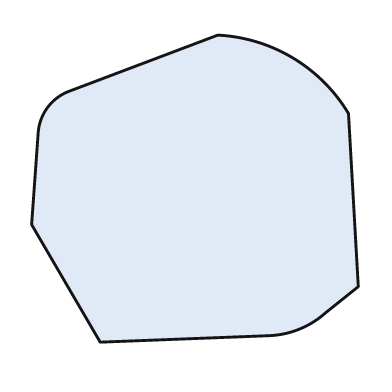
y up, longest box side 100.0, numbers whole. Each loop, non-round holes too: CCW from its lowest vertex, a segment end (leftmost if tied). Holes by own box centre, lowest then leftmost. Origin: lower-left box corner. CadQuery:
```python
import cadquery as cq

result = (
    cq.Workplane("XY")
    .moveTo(21.0, 0.0)
    .lineTo(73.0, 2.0)
    .threePointArc((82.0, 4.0), (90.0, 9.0))
    .lineTo(100.0, 17.0)
    .lineTo(97.0, 70.0)
    .threePointArc((80.0, 87.0), (57.0, 94.0))
    .lineTo(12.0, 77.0)
    .threePointArc((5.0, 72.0), (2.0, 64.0))
    .lineTo(0.0, 36.0)
    .close()
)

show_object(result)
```